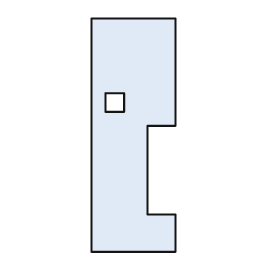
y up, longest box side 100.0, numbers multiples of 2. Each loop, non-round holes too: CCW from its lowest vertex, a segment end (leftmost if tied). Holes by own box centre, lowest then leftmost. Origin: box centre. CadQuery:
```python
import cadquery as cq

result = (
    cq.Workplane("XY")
    .moveTo(-18.0, -50.0)
    .lineTo(18.0, -50.0)
    .lineTo(18.0, -34.0)
    .lineTo(6.0, -34.0)
    .lineTo(6.0, 4.0)
    .lineTo(18.0, 4.0)
    .lineTo(18.0, 50.0)
    .lineTo(-18.0, 50.0)
    .close()
    .moveTo(-12.0, 10.0)
    .lineTo(-4.0, 10.0)
    .lineTo(-4.0, 18.0)
    .lineTo(-12.0, 18.0)
    .close()
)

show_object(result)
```